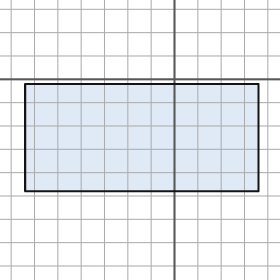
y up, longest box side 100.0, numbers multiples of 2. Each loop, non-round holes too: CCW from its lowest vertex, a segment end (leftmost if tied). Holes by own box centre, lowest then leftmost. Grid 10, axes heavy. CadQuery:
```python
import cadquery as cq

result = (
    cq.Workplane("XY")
    .moveTo(-64.0, -48.0)
    .lineTo(36.0, -48.0)
    .lineTo(36.0, -2.0)
    .lineTo(-64.0, -2.0)
    .close()
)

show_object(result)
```